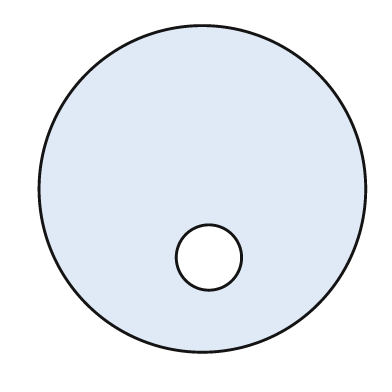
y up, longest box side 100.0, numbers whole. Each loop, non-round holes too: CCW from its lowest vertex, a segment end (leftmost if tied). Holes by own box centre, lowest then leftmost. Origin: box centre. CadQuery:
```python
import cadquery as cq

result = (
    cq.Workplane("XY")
    .moveTo(0.0, 0.0)
    .circle(50.0)
    .moveTo(2.0, -21.0)
    .circle(10.0)
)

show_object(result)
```